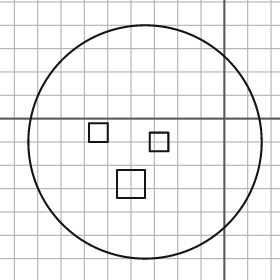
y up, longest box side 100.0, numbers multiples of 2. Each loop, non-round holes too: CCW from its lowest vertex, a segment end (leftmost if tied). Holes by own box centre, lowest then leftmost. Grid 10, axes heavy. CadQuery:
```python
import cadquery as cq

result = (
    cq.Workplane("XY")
    .moveTo(-34.0, -10.0)
    .circle(50.0)
    .moveTo(-46.0, -34.0)
    .lineTo(-34.0, -34.0)
    .lineTo(-34.0, -22.0)
    .lineTo(-46.0, -22.0)
    .close()
    .moveTo(-32.0, -14.0)
    .lineTo(-24.0, -14.0)
    .lineTo(-24.0, -6.0)
    .lineTo(-32.0, -6.0)
    .close()
    .moveTo(-58.0, -10.0)
    .lineTo(-50.0, -10.0)
    .lineTo(-50.0, -2.0)
    .lineTo(-58.0, -2.0)
    .close()
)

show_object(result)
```